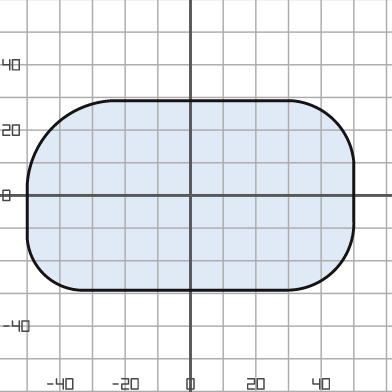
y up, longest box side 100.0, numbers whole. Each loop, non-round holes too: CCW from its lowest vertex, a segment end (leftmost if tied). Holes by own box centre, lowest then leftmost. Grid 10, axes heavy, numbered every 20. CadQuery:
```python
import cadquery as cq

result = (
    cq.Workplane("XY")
    .moveTo(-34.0, -29.0)
    .lineTo(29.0, -29.0)
    .threePointArc((44.0, -23.0), (50.0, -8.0))
    .lineTo(50.0, 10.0)
    .threePointArc((44.0, 23.0), (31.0, 29.0))
    .lineTo(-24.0, 29.0)
    .threePointArc((-42.0, 21.0), (-50.0, 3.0))
    .lineTo(-50.0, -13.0)
    .threePointArc((-45.0, -24.0), (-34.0, -29.0))
    .close()
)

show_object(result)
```